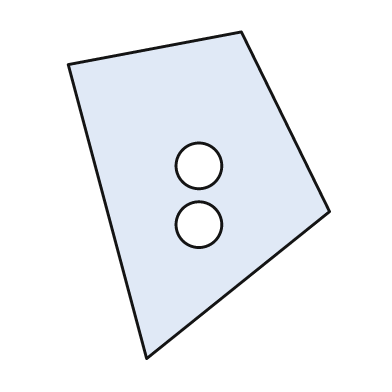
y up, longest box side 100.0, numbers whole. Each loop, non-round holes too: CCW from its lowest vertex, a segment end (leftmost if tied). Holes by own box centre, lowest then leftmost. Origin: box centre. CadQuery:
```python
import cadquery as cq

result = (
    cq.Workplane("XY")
    .moveTo(-16.0, -50.0)
    .lineTo(40.0, -5.0)
    .lineTo(13.0, 50.0)
    .lineTo(-40.0, 40.0)
    .close()
    .moveTo(0.0, -9.0)
    .circle(7.0)
    .moveTo(0.0, 9.0)
    .circle(7.0)
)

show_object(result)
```